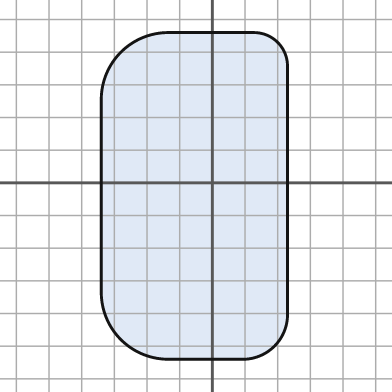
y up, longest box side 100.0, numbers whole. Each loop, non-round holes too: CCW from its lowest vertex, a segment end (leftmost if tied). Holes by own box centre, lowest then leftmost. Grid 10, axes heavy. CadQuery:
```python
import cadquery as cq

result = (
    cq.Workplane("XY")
    .moveTo(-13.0, -54.0)
    .lineTo(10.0, -54.0)
    .threePointArc((19.0, -50.0), (23.0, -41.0))
    .lineTo(23.0, 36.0)
    .threePointArc((20.0, 43.0), (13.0, 46.0))
    .lineTo(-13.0, 46.0)
    .threePointArc((-28.0, 40.0), (-34.0, 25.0))
    .lineTo(-34.0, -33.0)
    .threePointArc((-28.0, -48.0), (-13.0, -54.0))
    .close()
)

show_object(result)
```